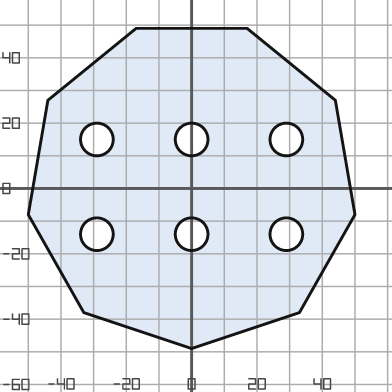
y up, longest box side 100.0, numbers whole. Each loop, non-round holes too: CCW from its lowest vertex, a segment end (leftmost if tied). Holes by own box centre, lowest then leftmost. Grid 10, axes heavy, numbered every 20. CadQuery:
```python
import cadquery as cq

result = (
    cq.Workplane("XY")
    .moveTo(0.0, -49.0)
    .lineTo(33.0, -38.0)
    .lineTo(50.0, -8.0)
    .lineTo(44.0, 27.0)
    .lineTo(17.0, 49.0)
    .lineTo(-17.0, 49.0)
    .lineTo(-44.0, 27.0)
    .lineTo(-50.0, -8.0)
    .lineTo(-33.0, -38.0)
    .close()
    .moveTo(-29.0, -14.0)
    .circle(5.0)
    .moveTo(0.0, -14.0)
    .circle(5.0)
    .moveTo(29.0, -14.0)
    .circle(5.0)
    .moveTo(-29.0, 15.0)
    .circle(5.0)
    .moveTo(0.0, 15.0)
    .circle(5.0)
    .moveTo(29.0, 15.0)
    .circle(5.0)
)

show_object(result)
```